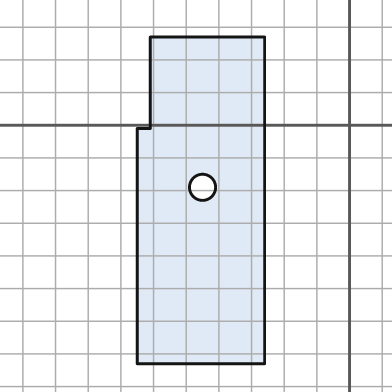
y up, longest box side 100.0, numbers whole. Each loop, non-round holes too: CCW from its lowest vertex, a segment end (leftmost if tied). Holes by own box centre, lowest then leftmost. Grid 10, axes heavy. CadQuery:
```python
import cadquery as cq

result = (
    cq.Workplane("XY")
    .moveTo(-65.0, -73.0)
    .lineTo(-26.0, -73.0)
    .lineTo(-26.0, 27.0)
    .lineTo(-61.0, 27.0)
    .lineTo(-61.0, -1.0)
    .lineTo(-65.0, -1.0)
    .close()
    .moveTo(-45.0, -19.0)
    .circle(4.0)
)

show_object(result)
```